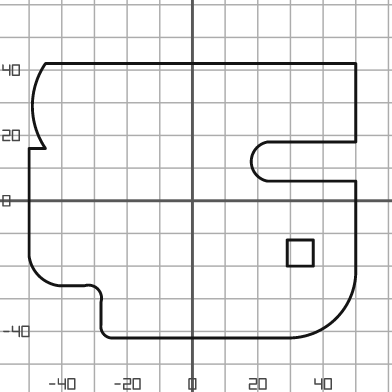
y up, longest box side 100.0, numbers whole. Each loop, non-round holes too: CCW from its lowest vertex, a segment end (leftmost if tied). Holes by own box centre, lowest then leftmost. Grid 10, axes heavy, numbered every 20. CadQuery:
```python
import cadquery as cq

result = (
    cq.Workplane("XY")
    .moveTo(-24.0, -42.0)
    .lineTo(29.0, -42.0)
    .threePointArc((44.0, -36.0), (50.0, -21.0))
    .lineTo(50.0, 6.0)
    .lineTo(23.0, 6.0)
    .threePointArc((18.0, 12.0), (23.0, 18.0))
    .lineTo(50.0, 18.0)
    .lineTo(50.0, 42.0)
    .lineTo(-45.0, 42.0)
    .threePointArc((-49.0, 29.0), (-45.0, 16.0))
    .lineTo(-50.0, 16.0)
    .lineTo(-50.0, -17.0)
    .threePointArc((-47.0, -23.0), (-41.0, -26.0))
    .lineTo(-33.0, -26.0)
    .threePointArc((-29.0, -27.0), (-28.0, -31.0))
    .lineTo(-28.0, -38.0)
    .threePointArc((-27.0, -41.0), (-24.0, -42.0))
    .close()
    .moveTo(29.0, -20.0)
    .lineTo(37.0, -20.0)
    .lineTo(37.0, -12.0)
    .lineTo(29.0, -12.0)
    .close()
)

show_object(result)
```